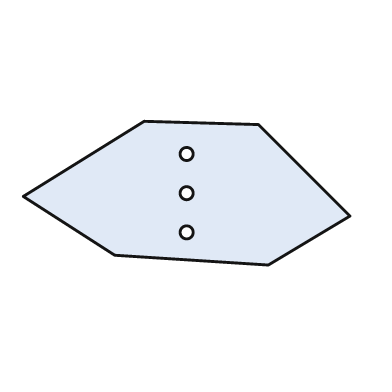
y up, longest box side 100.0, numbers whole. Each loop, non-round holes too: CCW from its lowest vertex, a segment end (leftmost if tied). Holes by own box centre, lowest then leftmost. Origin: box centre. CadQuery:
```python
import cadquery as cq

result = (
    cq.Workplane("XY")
    .moveTo(25.0, -22.0)
    .lineTo(50.0, -7.0)
    .lineTo(22.0, 21.0)
    .lineTo(-13.0, 22.0)
    .lineTo(-50.0, -1.0)
    .lineTo(-22.0, -19.0)
    .close()
    .moveTo(0.0, -12.0)
    .circle(2.0)
    .moveTo(0.0, 0.0)
    .circle(2.0)
    .moveTo(0.0, 12.0)
    .circle(2.0)
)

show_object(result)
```